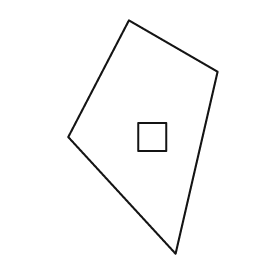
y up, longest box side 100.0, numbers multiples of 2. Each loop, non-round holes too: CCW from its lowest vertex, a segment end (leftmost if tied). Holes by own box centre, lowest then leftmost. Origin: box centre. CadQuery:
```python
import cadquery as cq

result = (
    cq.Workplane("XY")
    .moveTo(14.0, -50.0)
    .lineTo(32.0, 28.0)
    .lineTo(-6.0, 50.0)
    .lineTo(-32.0, 0.0)
    .close()
    .moveTo(-2.0, -6.0)
    .lineTo(10.0, -6.0)
    .lineTo(10.0, 6.0)
    .lineTo(-2.0, 6.0)
    .close()
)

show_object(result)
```